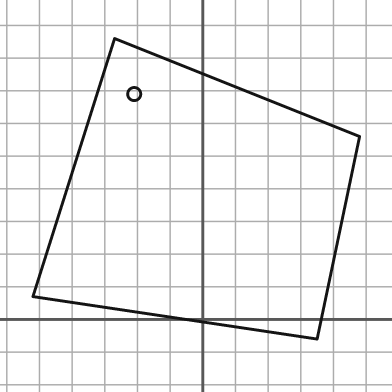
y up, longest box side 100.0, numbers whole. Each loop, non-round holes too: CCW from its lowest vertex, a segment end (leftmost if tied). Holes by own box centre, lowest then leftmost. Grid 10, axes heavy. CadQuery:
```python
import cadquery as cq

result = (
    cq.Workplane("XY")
    .moveTo(35.0, -6.0)
    .lineTo(48.0, 56.0)
    .lineTo(-27.0, 86.0)
    .lineTo(-52.0, 7.0)
    .close()
    .moveTo(-21.0, 69.0)
    .circle(2.0)
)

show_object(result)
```